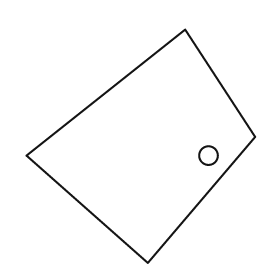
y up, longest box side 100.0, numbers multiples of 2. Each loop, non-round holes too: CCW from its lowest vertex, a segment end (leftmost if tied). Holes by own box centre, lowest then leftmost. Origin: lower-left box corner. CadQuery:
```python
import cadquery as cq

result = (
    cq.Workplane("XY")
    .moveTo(52.0, 0.0)
    .lineTo(98.0, 54.0)
    .lineTo(68.0, 100.0)
    .lineTo(0.0, 46.0)
    .close()
    .moveTo(78.0, 46.0)
    .circle(4.0)
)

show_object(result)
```